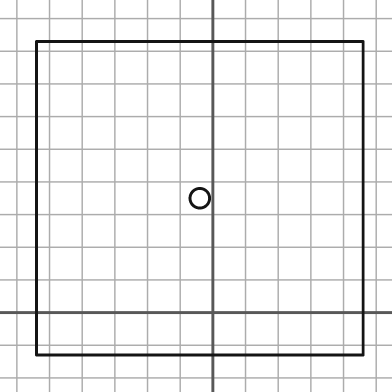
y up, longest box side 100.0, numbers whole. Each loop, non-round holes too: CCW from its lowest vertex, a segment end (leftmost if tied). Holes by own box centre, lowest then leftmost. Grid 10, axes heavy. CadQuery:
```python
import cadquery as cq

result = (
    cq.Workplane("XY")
    .moveTo(-54.0, -13.0)
    .lineTo(46.0, -13.0)
    .lineTo(46.0, 83.0)
    .lineTo(-54.0, 83.0)
    .close()
    .moveTo(-4.0, 35.0)
    .circle(3.0)
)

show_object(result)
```